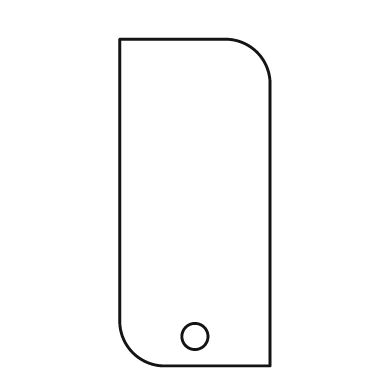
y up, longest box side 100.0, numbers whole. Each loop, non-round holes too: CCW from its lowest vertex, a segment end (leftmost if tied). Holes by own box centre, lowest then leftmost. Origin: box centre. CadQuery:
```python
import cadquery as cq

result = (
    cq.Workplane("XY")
    .moveTo(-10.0, -50.0)
    .lineTo(23.0, -50.0)
    .lineTo(23.0, 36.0)
    .threePointArc((19.0, 46.0), (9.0, 50.0))
    .lineTo(-23.0, 50.0)
    .lineTo(-23.0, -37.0)
    .threePointArc((-19.0, -46.0), (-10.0, -50.0))
    .close()
    .moveTo(0.0, -41.0)
    .circle(4.0)
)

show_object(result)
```